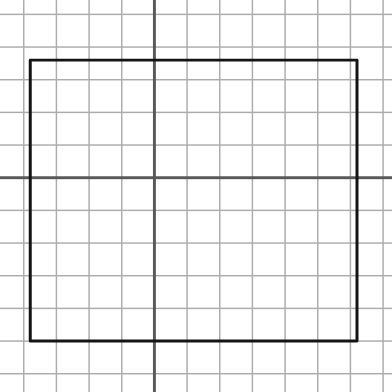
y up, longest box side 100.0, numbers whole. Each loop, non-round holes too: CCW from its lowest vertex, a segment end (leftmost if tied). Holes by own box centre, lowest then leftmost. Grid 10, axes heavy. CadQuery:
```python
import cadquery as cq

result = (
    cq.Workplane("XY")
    .moveTo(-38.0, -50.0)
    .lineTo(62.0, -50.0)
    .lineTo(62.0, 36.0)
    .lineTo(-38.0, 36.0)
    .close()
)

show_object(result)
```